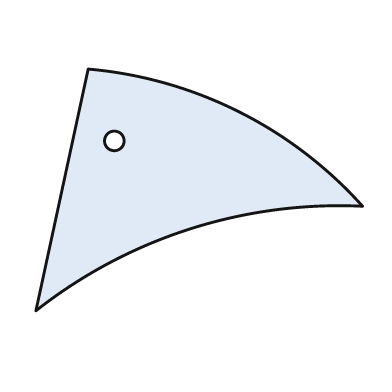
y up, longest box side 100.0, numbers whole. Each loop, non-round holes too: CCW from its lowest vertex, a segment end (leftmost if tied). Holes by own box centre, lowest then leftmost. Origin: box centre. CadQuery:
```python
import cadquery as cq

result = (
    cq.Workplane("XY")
    .moveTo(-50.0, -37.0)
    .threePointArc((-3.0, -12.0), (50.0, -5.0))
    .threePointArc((12.0, 24.0), (-34.0, 37.0))
    .close()
    .moveTo(-26.0, 15.0)
    .circle(3.0)
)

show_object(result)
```